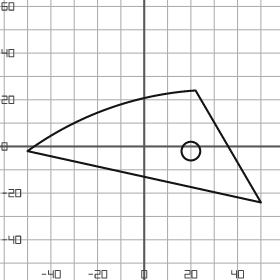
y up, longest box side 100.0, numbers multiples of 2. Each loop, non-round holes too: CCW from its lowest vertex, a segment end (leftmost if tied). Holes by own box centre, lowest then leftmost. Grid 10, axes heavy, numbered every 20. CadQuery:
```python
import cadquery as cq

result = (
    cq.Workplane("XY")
    .moveTo(50.0, -24.0)
    .lineTo(22.0, 24.0)
    .threePointArc((-16.0, 16.0), (-50.0, -2.0))
    .close()
    .moveTo(20.0, -2.0)
    .circle(4.0)
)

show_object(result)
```